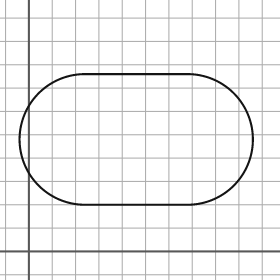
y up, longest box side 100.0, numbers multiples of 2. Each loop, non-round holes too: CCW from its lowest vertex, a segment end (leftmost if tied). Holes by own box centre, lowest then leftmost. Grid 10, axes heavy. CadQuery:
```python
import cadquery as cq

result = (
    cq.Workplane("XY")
    .moveTo(24.0, 20.0)
    .lineTo(68.0, 20.0)
    .threePointArc((96.0, 48.0), (68.0, 76.0))
    .lineTo(24.0, 76.0)
    .threePointArc((-4.0, 48.0), (24.0, 20.0))
    .close()
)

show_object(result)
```